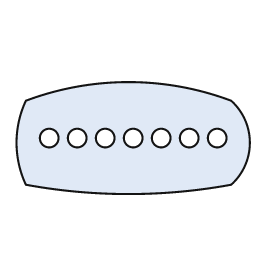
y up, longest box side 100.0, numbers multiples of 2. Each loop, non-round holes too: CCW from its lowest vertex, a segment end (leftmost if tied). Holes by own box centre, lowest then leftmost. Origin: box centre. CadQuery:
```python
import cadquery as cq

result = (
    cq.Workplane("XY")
    .moveTo(-46.0, -20.0)
    .threePointArc((-2.0, -24.0), (42.0, -20.0))
    .threePointArc((50.0, -2.0), (42.0, 16.0))
    .threePointArc((-2.0, 24.0), (-46.0, 16.0))
    .threePointArc((-50.0, -2.0), (-46.0, -20.0))
    .close()
    .moveTo(-36.0, 0.0)
    .circle(4.0)
    .moveTo(-24.0, 0.0)
    .circle(4.0)
    .moveTo(-12.0, 0.0)
    .circle(4.0)
    .moveTo(0.0, 0.0)
    .circle(4.0)
    .moveTo(12.0, 0.0)
    .circle(4.0)
    .moveTo(24.0, 0.0)
    .circle(4.0)
    .moveTo(36.0, 0.0)
    .circle(4.0)
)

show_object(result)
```